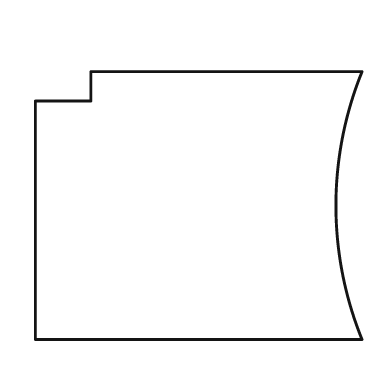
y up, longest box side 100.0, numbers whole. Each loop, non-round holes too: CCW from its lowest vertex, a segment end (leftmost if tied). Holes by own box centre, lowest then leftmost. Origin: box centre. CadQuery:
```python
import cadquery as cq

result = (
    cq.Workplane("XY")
    .moveTo(-50.0, -41.0)
    .lineTo(50.0, -41.0)
    .threePointArc((42.0, 0.0), (50.0, 41.0))
    .lineTo(-33.0, 41.0)
    .lineTo(-33.0, 32.0)
    .lineTo(-50.0, 32.0)
    .close()
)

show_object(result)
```